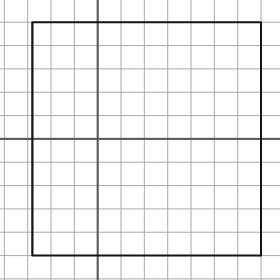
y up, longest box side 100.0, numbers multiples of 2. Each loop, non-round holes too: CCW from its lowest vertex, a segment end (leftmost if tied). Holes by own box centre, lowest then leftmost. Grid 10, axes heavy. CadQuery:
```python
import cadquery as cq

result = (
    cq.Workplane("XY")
    .moveTo(-28.0, -50.0)
    .lineTo(70.0, -50.0)
    .lineTo(70.0, 50.0)
    .lineTo(-28.0, 50.0)
    .close()
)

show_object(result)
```